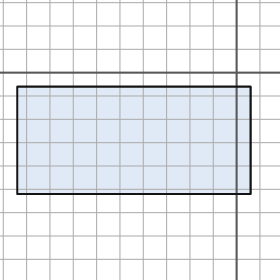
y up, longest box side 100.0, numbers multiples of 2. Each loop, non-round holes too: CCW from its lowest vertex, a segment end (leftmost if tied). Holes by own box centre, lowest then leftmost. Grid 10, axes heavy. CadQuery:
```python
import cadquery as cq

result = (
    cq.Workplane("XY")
    .moveTo(-94.0, -52.0)
    .lineTo(6.0, -52.0)
    .lineTo(6.0, -6.0)
    .lineTo(-94.0, -6.0)
    .close()
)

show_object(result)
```